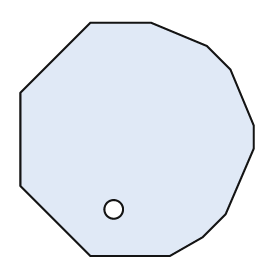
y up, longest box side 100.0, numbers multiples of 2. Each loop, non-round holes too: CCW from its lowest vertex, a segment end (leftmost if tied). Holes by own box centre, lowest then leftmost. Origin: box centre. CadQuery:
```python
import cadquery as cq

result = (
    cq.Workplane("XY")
    .moveTo(-20.0, -50.0)
    .lineTo(14.0, -50.0)
    .lineTo(28.0, -42.0)
    .lineTo(38.0, -32.0)
    .lineTo(50.0, -4.0)
    .lineTo(50.0, 6.0)
    .lineTo(40.0, 30.0)
    .lineTo(30.0, 40.0)
    .lineTo(6.0, 50.0)
    .lineTo(-20.0, 50.0)
    .lineTo(-50.0, 20.0)
    .lineTo(-50.0, -20.0)
    .close()
    .moveTo(-10.0, -30.0)
    .circle(4.0)
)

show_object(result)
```